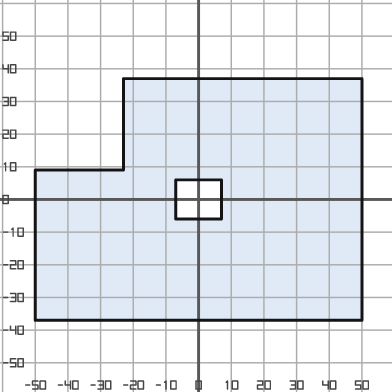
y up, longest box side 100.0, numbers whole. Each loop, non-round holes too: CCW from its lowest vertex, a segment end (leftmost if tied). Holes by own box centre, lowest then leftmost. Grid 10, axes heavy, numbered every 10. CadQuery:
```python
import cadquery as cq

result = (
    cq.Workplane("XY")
    .moveTo(-50.0, -37.0)
    .lineTo(50.0, -37.0)
    .lineTo(50.0, 37.0)
    .lineTo(-23.0, 37.0)
    .lineTo(-23.0, 9.0)
    .lineTo(-50.0, 9.0)
    .close()
    .moveTo(-7.0, -6.0)
    .lineTo(7.0, -6.0)
    .lineTo(7.0, 6.0)
    .lineTo(-7.0, 6.0)
    .close()
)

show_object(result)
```